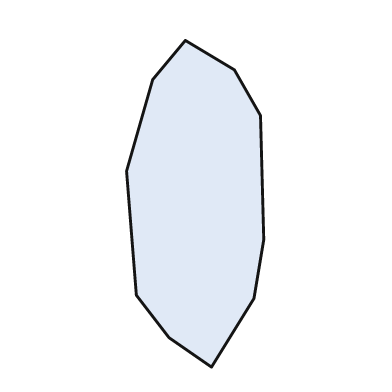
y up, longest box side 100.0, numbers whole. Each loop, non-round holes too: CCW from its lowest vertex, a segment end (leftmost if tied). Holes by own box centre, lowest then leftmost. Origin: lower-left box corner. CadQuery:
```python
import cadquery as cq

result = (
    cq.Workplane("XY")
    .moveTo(26.0, 0.0)
    .lineTo(39.0, 21.0)
    .lineTo(42.0, 39.0)
    .lineTo(41.0, 77.0)
    .lineTo(33.0, 91.0)
    .lineTo(18.0, 100.0)
    .lineTo(8.0, 88.0)
    .lineTo(0.0, 60.0)
    .lineTo(3.0, 22.0)
    .lineTo(13.0, 9.0)
    .close()
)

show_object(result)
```